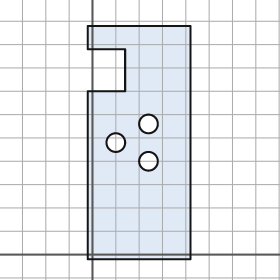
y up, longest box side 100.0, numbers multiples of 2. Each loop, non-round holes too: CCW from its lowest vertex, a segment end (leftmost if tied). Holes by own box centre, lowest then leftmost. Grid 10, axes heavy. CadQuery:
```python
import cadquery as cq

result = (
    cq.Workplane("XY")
    .moveTo(-2.0, -2.0)
    .lineTo(42.0, -2.0)
    .lineTo(42.0, 98.0)
    .lineTo(-2.0, 98.0)
    .lineTo(-2.0, 88.0)
    .lineTo(14.0, 88.0)
    .lineTo(14.0, 70.0)
    .lineTo(-2.0, 70.0)
    .close()
    .moveTo(24.0, 40.0)
    .circle(4.0)
    .moveTo(10.0, 48.0)
    .circle(4.0)
    .moveTo(24.0, 56.0)
    .circle(4.0)
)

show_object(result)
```